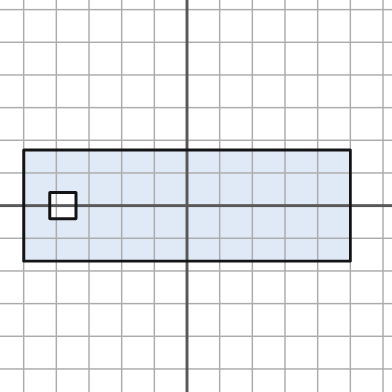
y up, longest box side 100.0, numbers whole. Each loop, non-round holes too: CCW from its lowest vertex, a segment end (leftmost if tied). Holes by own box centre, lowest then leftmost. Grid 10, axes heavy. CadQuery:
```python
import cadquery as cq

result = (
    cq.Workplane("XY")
    .moveTo(-50.0, -17.0)
    .lineTo(50.0, -17.0)
    .lineTo(50.0, 17.0)
    .lineTo(-50.0, 17.0)
    .close()
    .moveTo(-42.0, -4.0)
    .lineTo(-34.0, -4.0)
    .lineTo(-34.0, 4.0)
    .lineTo(-42.0, 4.0)
    .close()
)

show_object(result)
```